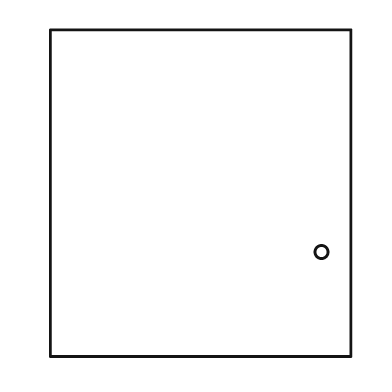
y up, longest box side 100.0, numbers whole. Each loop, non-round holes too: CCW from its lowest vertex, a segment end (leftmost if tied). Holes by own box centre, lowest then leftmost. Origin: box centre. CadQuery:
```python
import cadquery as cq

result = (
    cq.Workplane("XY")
    .moveTo(-46.0, -50.0)
    .lineTo(46.0, -50.0)
    .lineTo(46.0, 50.0)
    .lineTo(-46.0, 50.0)
    .close()
    .moveTo(37.0, -18.0)
    .circle(2.0)
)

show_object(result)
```